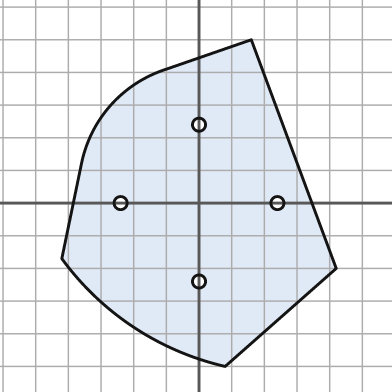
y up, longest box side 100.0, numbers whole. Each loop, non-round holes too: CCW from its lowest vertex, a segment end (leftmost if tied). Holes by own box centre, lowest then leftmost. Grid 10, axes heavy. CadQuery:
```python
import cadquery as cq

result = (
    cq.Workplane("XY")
    .moveTo(8.0, -50.0)
    .lineTo(42.0, -20.0)
    .lineTo(16.0, 50.0)
    .lineTo(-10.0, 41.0)
    .threePointArc((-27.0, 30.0), (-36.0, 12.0))
    .lineTo(-42.0, -17.0)
    .threePointArc((-20.0, -38.0), (8.0, -50.0))
    .close()
    .moveTo(0.0, -24.0)
    .circle(2.0)
    .moveTo(-24.0, 0.0)
    .circle(2.0)
    .moveTo(24.0, 0.0)
    .circle(2.0)
    .moveTo(0.0, 24.0)
    .circle(2.0)
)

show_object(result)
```